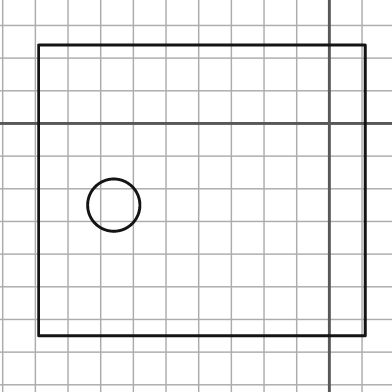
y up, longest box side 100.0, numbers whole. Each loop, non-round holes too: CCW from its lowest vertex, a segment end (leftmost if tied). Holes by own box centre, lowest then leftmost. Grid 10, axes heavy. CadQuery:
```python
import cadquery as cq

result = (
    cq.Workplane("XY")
    .moveTo(-89.0, -65.0)
    .lineTo(11.0, -65.0)
    .lineTo(11.0, 24.0)
    .lineTo(-89.0, 24.0)
    .close()
    .moveTo(-66.0, -25.0)
    .circle(8.0)
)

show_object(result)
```